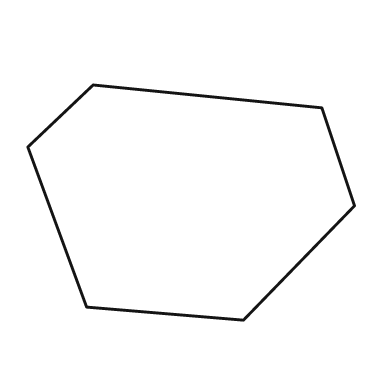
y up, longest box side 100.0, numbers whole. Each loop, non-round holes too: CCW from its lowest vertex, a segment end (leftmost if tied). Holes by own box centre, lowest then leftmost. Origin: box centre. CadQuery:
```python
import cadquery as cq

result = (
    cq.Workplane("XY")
    .moveTo(16.0, -36.0)
    .lineTo(50.0, -1.0)
    .lineTo(40.0, 29.0)
    .lineTo(-30.0, 36.0)
    .lineTo(-50.0, 17.0)
    .lineTo(-32.0, -32.0)
    .close()
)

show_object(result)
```